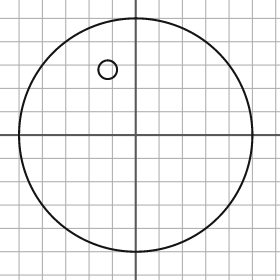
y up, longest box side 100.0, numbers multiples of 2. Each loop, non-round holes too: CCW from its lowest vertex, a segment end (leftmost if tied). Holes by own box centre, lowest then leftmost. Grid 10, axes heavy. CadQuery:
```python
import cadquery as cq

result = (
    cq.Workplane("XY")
    .moveTo(0.0, 0.0)
    .circle(50.0)
    .moveTo(-12.0, 28.0)
    .circle(4.0)
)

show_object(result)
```